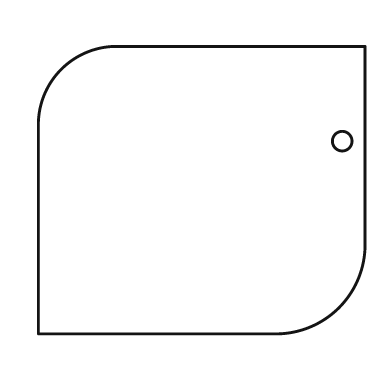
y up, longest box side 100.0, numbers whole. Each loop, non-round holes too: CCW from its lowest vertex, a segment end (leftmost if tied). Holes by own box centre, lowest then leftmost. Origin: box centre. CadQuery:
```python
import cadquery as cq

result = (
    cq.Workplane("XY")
    .moveTo(-50.0, -44.0)
    .lineTo(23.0, -44.0)
    .threePointArc((42.0, -36.0), (50.0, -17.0))
    .lineTo(50.0, 44.0)
    .lineTo(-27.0, 44.0)
    .threePointArc((-43.0, 37.0), (-50.0, 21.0))
    .close()
    .moveTo(43.0, 15.0)
    .circle(3.0)
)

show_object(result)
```